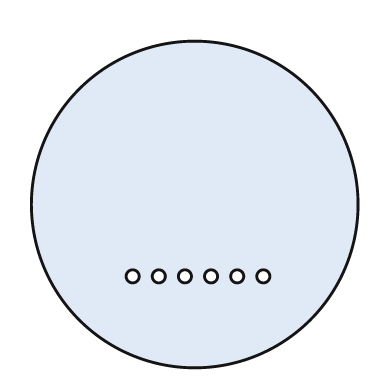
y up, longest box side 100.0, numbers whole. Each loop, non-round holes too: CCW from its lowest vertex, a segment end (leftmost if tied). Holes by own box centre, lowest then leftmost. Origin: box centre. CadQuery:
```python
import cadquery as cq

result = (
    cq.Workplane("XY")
    .moveTo(0.0, 0.0)
    .circle(50.0)
    .moveTo(-19.0, -22.0)
    .circle(2.0)
    .moveTo(-11.0, -22.0)
    .circle(2.0)
    .moveTo(-3.0, -22.0)
    .circle(2.0)
    .moveTo(5.0, -22.0)
    .circle(2.0)
    .moveTo(13.0, -22.0)
    .circle(2.0)
    .moveTo(21.0, -22.0)
    .circle(2.0)
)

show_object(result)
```